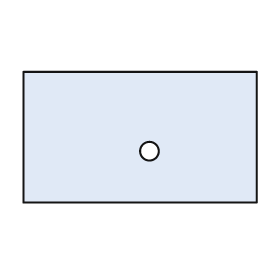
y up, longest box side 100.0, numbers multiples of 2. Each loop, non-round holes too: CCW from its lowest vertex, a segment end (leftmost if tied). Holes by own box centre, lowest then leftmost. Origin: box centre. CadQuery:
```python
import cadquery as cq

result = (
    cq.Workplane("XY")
    .moveTo(-50.0, -28.0)
    .lineTo(50.0, -28.0)
    .lineTo(50.0, 28.0)
    .lineTo(-50.0, 28.0)
    .close()
    .moveTo(4.0, -6.0)
    .circle(4.0)
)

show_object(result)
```